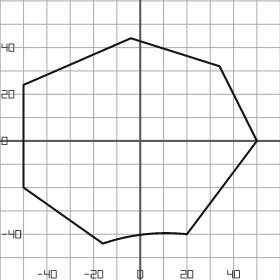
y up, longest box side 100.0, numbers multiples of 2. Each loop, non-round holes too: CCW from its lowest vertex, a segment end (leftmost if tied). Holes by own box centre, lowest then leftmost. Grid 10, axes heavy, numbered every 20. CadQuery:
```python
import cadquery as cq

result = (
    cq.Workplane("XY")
    .moveTo(-16.0, -44.0)
    .threePointArc((2.0, -40.0), (20.0, -40.0))
    .lineTo(50.0, 0.0)
    .lineTo(34.0, 32.0)
    .lineTo(-4.0, 44.0)
    .lineTo(-50.0, 24.0)
    .lineTo(-50.0, -20.0)
    .close()
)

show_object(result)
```